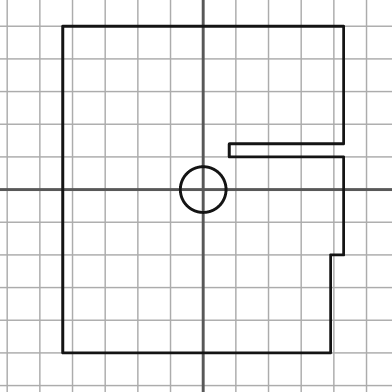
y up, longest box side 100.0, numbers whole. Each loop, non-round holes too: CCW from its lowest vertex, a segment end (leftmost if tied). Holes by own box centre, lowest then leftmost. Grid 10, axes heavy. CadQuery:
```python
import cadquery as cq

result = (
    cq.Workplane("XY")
    .moveTo(-43.0, -50.0)
    .lineTo(39.0, -50.0)
    .lineTo(39.0, -20.0)
    .lineTo(43.0, -20.0)
    .lineTo(43.0, 10.0)
    .lineTo(8.0, 10.0)
    .lineTo(8.0, 14.0)
    .lineTo(43.0, 14.0)
    .lineTo(43.0, 50.0)
    .lineTo(-43.0, 50.0)
    .close()
    .moveTo(0.0, 0.0)
    .circle(7.0)
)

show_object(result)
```